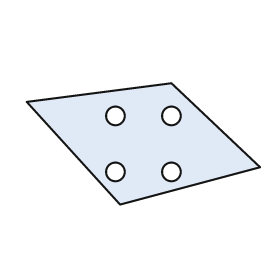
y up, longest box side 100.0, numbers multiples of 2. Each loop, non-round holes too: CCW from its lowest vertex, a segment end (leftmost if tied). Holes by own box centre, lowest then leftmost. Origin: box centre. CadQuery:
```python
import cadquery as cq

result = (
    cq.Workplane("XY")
    .moveTo(-10.0, -26.0)
    .lineTo(50.0, -10.0)
    .lineTo(12.0, 26.0)
    .lineTo(-50.0, 18.0)
    .close()
    .moveTo(-12.0, -12.0)
    .circle(4.0)
    .moveTo(12.0, -12.0)
    .circle(4.0)
    .moveTo(-12.0, 12.0)
    .circle(4.0)
    .moveTo(12.0, 12.0)
    .circle(4.0)
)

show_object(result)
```